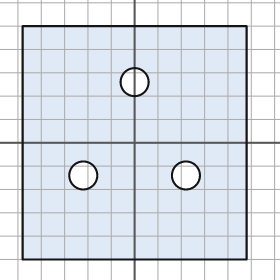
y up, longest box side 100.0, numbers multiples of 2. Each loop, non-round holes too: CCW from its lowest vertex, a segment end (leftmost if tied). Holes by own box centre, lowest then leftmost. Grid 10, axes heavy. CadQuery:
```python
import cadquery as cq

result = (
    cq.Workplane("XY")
    .moveTo(-48.0, -50.0)
    .lineTo(48.0, -50.0)
    .lineTo(48.0, 50.0)
    .lineTo(-48.0, 50.0)
    .close()
    .moveTo(-22.0, -14.0)
    .circle(6.0)
    .moveTo(22.0, -14.0)
    .circle(6.0)
    .moveTo(0.0, 26.0)
    .circle(6.0)
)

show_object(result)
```